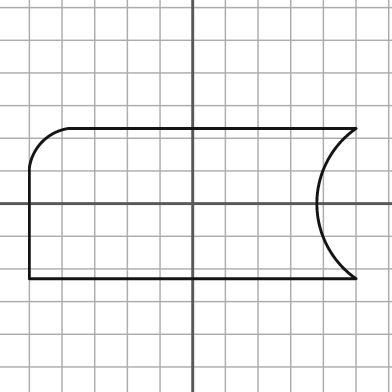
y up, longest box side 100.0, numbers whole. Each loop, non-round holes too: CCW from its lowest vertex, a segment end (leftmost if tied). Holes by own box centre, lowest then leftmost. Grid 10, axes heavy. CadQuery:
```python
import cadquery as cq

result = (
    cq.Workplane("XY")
    .moveTo(-50.0, -23.0)
    .lineTo(50.0, -23.0)
    .threePointArc((38.0, 0.0), (50.0, 23.0))
    .lineTo(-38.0, 23.0)
    .threePointArc((-46.0, 19.0), (-50.0, 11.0))
    .close()
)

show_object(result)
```